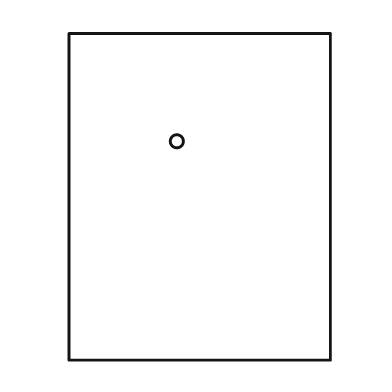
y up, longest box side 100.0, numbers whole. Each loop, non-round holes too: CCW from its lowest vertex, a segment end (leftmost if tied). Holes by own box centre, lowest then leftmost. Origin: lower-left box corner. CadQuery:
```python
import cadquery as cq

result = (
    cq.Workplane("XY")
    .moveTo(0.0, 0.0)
    .lineTo(80.0, 0.0)
    .lineTo(80.0, 100.0)
    .lineTo(0.0, 100.0)
    .close()
    .moveTo(33.0, 67.0)
    .circle(2.0)
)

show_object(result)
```